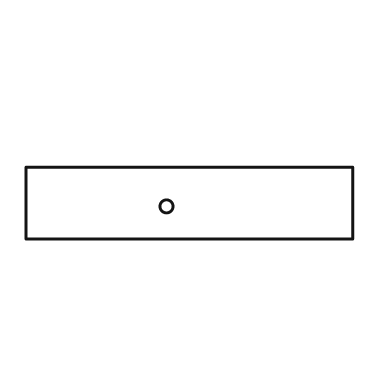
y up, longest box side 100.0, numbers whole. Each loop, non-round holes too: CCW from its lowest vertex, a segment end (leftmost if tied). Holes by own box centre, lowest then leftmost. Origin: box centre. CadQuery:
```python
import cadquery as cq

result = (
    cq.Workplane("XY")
    .moveTo(-50.0, -11.0)
    .lineTo(50.0, -11.0)
    .lineTo(50.0, 11.0)
    .lineTo(-50.0, 11.0)
    .close()
    .moveTo(-7.0, -1.0)
    .circle(2.0)
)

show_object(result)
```